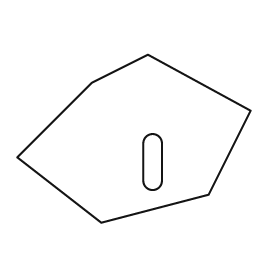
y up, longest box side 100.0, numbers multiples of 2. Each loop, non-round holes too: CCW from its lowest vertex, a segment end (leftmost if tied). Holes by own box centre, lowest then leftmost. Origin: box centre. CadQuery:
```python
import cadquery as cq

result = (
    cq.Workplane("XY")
    .moveTo(-14.0, -36.0)
    .lineTo(32.0, -24.0)
    .lineTo(50.0, 12.0)
    .lineTo(6.0, 36.0)
    .lineTo(-18.0, 24.0)
    .lineTo(-50.0, -8.0)
    .close()
    .moveTo(4.0, -18.0)
    .threePointArc((8.0, -22.0), (12.0, -18.0))
    .lineTo(12.0, -2.0)
    .threePointArc((8.0, 2.0), (4.0, -2.0))
    .close()
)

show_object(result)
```